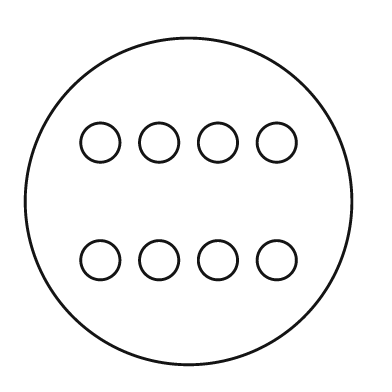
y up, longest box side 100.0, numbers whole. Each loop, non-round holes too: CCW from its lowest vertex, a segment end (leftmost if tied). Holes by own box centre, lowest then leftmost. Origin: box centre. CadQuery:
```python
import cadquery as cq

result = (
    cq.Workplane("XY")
    .moveTo(0.0, 0.0)
    .circle(50.0)
    .moveTo(-27.0, -18.0)
    .circle(6.0)
    .moveTo(-9.0, -18.0)
    .circle(6.0)
    .moveTo(9.0, -18.0)
    .circle(6.0)
    .moveTo(27.0, -18.0)
    .circle(6.0)
    .moveTo(-27.0, 18.0)
    .circle(6.0)
    .moveTo(-9.0, 18.0)
    .circle(6.0)
    .moveTo(9.0, 18.0)
    .circle(6.0)
    .moveTo(27.0, 18.0)
    .circle(6.0)
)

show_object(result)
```